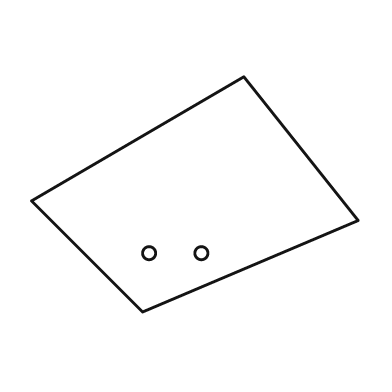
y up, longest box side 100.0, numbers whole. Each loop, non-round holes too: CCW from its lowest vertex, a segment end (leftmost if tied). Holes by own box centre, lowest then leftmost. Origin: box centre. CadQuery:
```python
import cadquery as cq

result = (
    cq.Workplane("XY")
    .moveTo(-16.0, -36.0)
    .lineTo(50.0, -8.0)
    .lineTo(15.0, 36.0)
    .lineTo(-50.0, -2.0)
    .close()
    .moveTo(-14.0, -18.0)
    .circle(2.0)
    .moveTo(2.0, -18.0)
    .circle(2.0)
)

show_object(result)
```